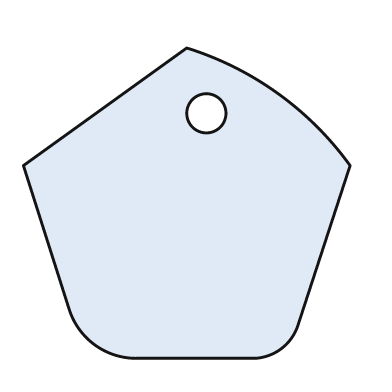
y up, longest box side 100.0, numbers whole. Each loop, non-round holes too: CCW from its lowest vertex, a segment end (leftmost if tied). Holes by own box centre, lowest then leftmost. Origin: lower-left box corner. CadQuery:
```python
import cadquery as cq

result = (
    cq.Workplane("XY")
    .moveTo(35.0, 0.0)
    .lineTo(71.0, 0.0)
    .threePointArc((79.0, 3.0), (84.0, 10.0))
    .lineTo(100.0, 59.0)
    .threePointArc((78.0, 81.0), (50.0, 95.0))
    .lineTo(0.0, 59.0)
    .lineTo(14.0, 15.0)
    .threePointArc((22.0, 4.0), (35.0, 0.0))
    .close()
    .moveTo(56.0, 75.0)
    .circle(6.0)
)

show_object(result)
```